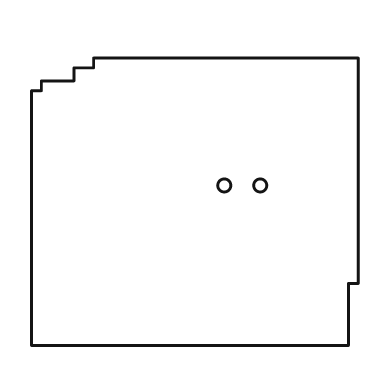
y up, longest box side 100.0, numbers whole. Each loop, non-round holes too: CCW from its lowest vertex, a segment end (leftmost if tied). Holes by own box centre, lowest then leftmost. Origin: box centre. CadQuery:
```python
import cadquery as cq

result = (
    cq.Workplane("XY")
    .moveTo(-50.0, -44.0)
    .lineTo(47.0, -44.0)
    .lineTo(47.0, -25.0)
    .lineTo(50.0, -25.0)
    .lineTo(50.0, 44.0)
    .lineTo(-31.0, 44.0)
    .lineTo(-31.0, 41.0)
    .lineTo(-37.0, 41.0)
    .lineTo(-37.0, 37.0)
    .lineTo(-47.0, 37.0)
    .lineTo(-47.0, 34.0)
    .lineTo(-50.0, 34.0)
    .close()
    .moveTo(9.0, 5.0)
    .circle(2.0)
    .moveTo(20.0, 5.0)
    .circle(2.0)
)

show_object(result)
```